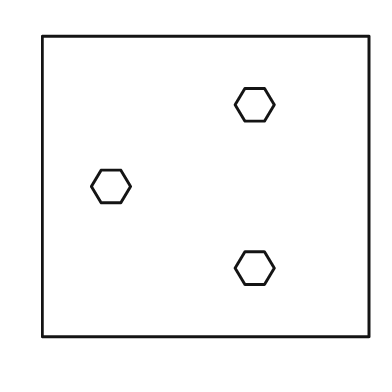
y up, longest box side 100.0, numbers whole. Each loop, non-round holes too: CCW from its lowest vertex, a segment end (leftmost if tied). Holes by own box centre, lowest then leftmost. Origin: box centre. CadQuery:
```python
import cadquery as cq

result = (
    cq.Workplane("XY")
    .moveTo(-50.0, -46.0)
    .lineTo(50.0, -46.0)
    .lineTo(50.0, 46.0)
    .lineTo(-50.0, 46.0)
    .close()
    .moveTo(12.0, -30.0)
    .lineTo(18.0, -30.0)
    .lineTo(21.0, -25.0)
    .lineTo(18.0, -20.0)
    .lineTo(12.0, -20.0)
    .lineTo(9.0, -25.0)
    .close()
    .moveTo(-32.0, -5.0)
    .lineTo(-26.0, -5.0)
    .lineTo(-23.0, 0.0)
    .lineTo(-26.0, 5.0)
    .lineTo(-32.0, 5.0)
    .lineTo(-35.0, 0.0)
    .close()
    .moveTo(12.0, 20.0)
    .lineTo(18.0, 20.0)
    .lineTo(21.0, 25.0)
    .lineTo(18.0, 30.0)
    .lineTo(12.0, 30.0)
    .lineTo(9.0, 25.0)
    .close()
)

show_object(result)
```